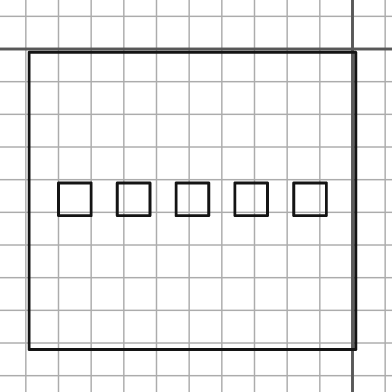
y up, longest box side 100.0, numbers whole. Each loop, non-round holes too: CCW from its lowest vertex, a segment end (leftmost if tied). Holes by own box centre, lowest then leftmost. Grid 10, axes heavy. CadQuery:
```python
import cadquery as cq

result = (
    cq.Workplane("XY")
    .moveTo(-99.0, -92.0)
    .lineTo(1.0, -92.0)
    .lineTo(1.0, -1.0)
    .lineTo(-99.0, -1.0)
    .close()
    .moveTo(-90.0, -51.0)
    .lineTo(-80.0, -51.0)
    .lineTo(-80.0, -41.0)
    .lineTo(-90.0, -41.0)
    .close()
    .moveTo(-72.0, -51.0)
    .lineTo(-62.0, -51.0)
    .lineTo(-62.0, -41.0)
    .lineTo(-72.0, -41.0)
    .close()
    .moveTo(-54.0, -51.0)
    .lineTo(-44.0, -51.0)
    .lineTo(-44.0, -41.0)
    .lineTo(-54.0, -41.0)
    .close()
    .moveTo(-36.0, -51.0)
    .lineTo(-26.0, -51.0)
    .lineTo(-26.0, -41.0)
    .lineTo(-36.0, -41.0)
    .close()
    .moveTo(-18.0, -51.0)
    .lineTo(-8.0, -51.0)
    .lineTo(-8.0, -41.0)
    .lineTo(-18.0, -41.0)
    .close()
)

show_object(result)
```